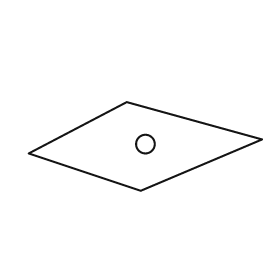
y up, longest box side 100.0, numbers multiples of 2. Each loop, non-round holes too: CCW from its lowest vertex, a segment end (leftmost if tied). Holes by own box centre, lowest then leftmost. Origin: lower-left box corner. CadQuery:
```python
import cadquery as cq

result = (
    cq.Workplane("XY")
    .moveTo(48.0, 0.0)
    .lineTo(100.0, 22.0)
    .lineTo(42.0, 38.0)
    .lineTo(0.0, 16.0)
    .close()
    .moveTo(50.0, 20.0)
    .circle(4.0)
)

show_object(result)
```